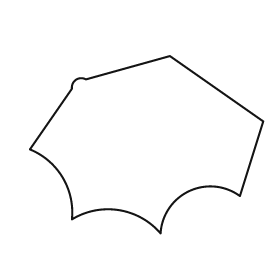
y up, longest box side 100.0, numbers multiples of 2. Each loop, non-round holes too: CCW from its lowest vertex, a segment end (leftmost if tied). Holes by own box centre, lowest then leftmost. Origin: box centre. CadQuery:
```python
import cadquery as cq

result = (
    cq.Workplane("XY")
    .moveTo(6.0, -38.0)
    .threePointArc((18.0, -20.0), (40.0, -22.0))
    .lineTo(50.0, 10.0)
    .lineTo(10.0, 38.0)
    .lineTo(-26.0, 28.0)
    .threePointArc((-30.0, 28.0), (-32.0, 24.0))
    .lineTo(-50.0, -2.0)
    .threePointArc((-36.0, -14.0), (-32.0, -32.0))
    .threePointArc((-12.0, -28.0), (6.0, -38.0))
    .close()
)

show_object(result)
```